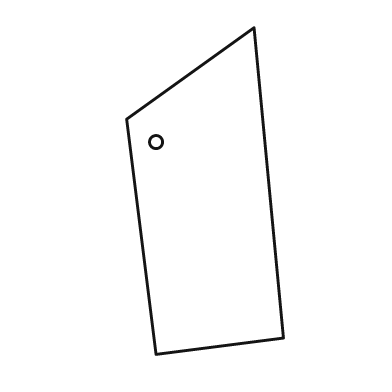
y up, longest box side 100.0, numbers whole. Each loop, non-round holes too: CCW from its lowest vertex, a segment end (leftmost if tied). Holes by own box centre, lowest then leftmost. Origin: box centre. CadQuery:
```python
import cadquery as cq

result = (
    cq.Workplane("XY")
    .moveTo(-15.0, -50.0)
    .lineTo(24.0, -45.0)
    .lineTo(15.0, 50.0)
    .lineTo(-24.0, 22.0)
    .close()
    .moveTo(-15.0, 15.0)
    .circle(2.0)
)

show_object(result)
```